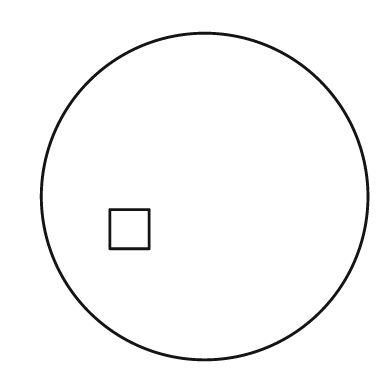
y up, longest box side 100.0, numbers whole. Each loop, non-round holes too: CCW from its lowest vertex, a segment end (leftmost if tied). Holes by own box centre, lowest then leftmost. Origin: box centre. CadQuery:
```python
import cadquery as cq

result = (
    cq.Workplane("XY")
    .moveTo(0.0, 0.0)
    .circle(50.0)
    .moveTo(-29.0, -16.0)
    .lineTo(-17.0, -16.0)
    .lineTo(-17.0, -4.0)
    .lineTo(-29.0, -4.0)
    .close()
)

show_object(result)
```